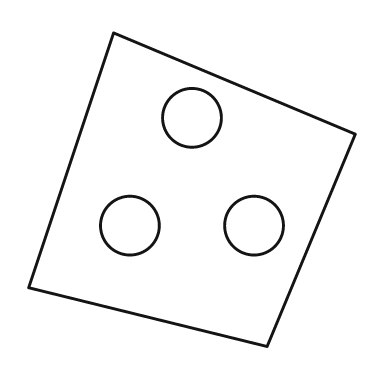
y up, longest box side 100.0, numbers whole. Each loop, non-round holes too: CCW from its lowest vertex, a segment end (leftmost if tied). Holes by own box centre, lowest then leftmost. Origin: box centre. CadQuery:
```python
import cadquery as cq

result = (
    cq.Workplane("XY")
    .moveTo(23.0, -48.0)
    .lineTo(50.0, 17.0)
    .lineTo(-24.0, 48.0)
    .lineTo(-50.0, -30.0)
    .close()
    .moveTo(-19.0, -11.0)
    .circle(9.0)
    .moveTo(19.0, -11.0)
    .circle(9.0)
    .moveTo(0.0, 22.0)
    .circle(9.0)
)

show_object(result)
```